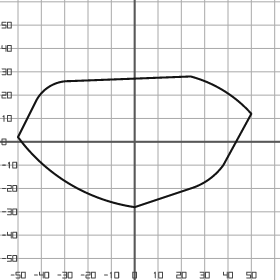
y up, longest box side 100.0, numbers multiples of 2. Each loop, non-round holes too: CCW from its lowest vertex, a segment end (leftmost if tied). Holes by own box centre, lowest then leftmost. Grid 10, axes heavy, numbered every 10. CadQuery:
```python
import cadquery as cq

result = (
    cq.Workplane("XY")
    .moveTo(0.0, -28.0)
    .lineTo(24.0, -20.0)
    .threePointArc((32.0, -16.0), (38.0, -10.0))
    .lineTo(50.0, 12.0)
    .threePointArc((38.0, 22.0), (24.0, 28.0))
    .lineTo(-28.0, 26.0)
    .threePointArc((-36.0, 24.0), (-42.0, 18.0))
    .lineTo(-50.0, 2.0)
    .threePointArc((-28.0, -18.0), (0.0, -28.0))
    .close()
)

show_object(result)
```